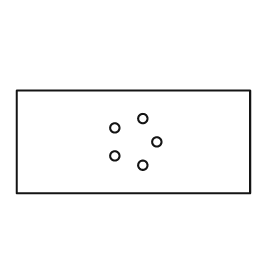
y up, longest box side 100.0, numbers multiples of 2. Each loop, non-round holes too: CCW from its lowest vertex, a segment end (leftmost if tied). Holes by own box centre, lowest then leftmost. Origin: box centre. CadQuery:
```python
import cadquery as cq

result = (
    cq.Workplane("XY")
    .moveTo(-50.0, -22.0)
    .lineTo(50.0, -22.0)
    .lineTo(50.0, 22.0)
    .lineTo(-50.0, 22.0)
    .close()
    .moveTo(4.0, -10.0)
    .circle(2.0)
    .moveTo(-8.0, -6.0)
    .circle(2.0)
    .moveTo(10.0, 0.0)
    .circle(2.0)
    .moveTo(-8.0, 6.0)
    .circle(2.0)
    .moveTo(4.0, 10.0)
    .circle(2.0)
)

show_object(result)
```